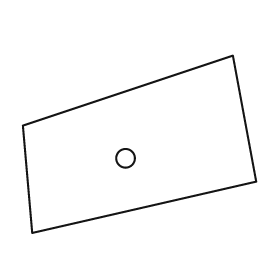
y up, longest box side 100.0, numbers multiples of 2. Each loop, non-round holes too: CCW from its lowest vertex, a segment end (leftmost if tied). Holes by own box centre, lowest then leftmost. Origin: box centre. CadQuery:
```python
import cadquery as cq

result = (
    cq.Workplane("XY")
    .moveTo(-46.0, -38.0)
    .lineTo(50.0, -16.0)
    .lineTo(40.0, 38.0)
    .lineTo(-50.0, 8.0)
    .close()
    .moveTo(-6.0, -6.0)
    .circle(4.0)
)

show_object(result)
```